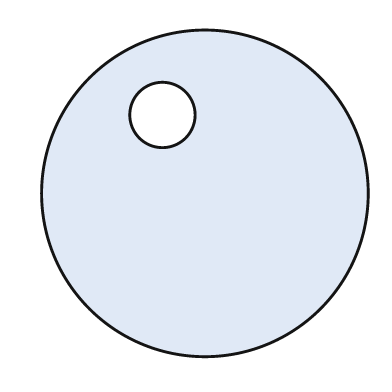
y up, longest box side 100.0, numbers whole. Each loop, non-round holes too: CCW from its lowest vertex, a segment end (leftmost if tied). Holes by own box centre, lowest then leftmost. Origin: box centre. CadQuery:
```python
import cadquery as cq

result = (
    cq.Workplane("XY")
    .moveTo(0.0, 0.0)
    .circle(50.0)
    .moveTo(-13.0, 24.0)
    .circle(10.0)
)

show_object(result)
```